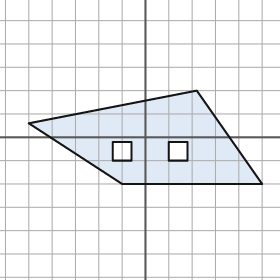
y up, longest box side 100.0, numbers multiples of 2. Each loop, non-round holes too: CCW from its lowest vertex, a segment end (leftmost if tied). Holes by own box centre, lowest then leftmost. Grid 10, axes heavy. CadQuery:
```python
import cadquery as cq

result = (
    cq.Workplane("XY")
    .moveTo(-10.0, -20.0)
    .lineTo(50.0, -20.0)
    .lineTo(22.0, 20.0)
    .lineTo(-50.0, 6.0)
    .close()
    .moveTo(-14.0, -10.0)
    .lineTo(-6.0, -10.0)
    .lineTo(-6.0, -2.0)
    .lineTo(-14.0, -2.0)
    .close()
    .moveTo(10.0, -10.0)
    .lineTo(18.0, -10.0)
    .lineTo(18.0, -2.0)
    .lineTo(10.0, -2.0)
    .close()
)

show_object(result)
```